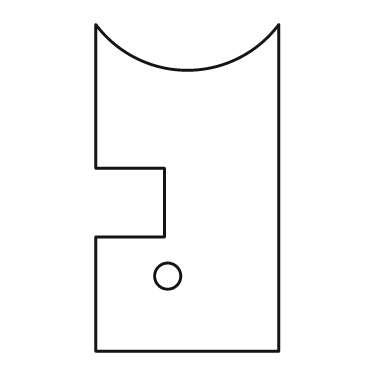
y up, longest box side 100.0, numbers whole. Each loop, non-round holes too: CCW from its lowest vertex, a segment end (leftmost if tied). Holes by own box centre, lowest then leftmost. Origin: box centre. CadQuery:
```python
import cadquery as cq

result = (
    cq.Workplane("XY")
    .moveTo(-28.0, -50.0)
    .lineTo(28.0, -50.0)
    .lineTo(28.0, 50.0)
    .threePointArc((0.0, 36.0), (-28.0, 50.0))
    .lineTo(-28.0, 6.0)
    .lineTo(-7.0, 6.0)
    .lineTo(-7.0, -15.0)
    .lineTo(-28.0, -15.0)
    .close()
    .moveTo(-6.0, -27.0)
    .circle(4.0)
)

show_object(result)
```